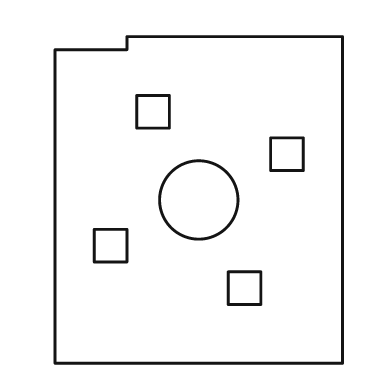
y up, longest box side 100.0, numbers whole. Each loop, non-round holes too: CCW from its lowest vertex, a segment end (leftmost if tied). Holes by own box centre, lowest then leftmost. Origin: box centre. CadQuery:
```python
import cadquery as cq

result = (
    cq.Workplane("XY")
    .moveTo(-44.0, -50.0)
    .lineTo(44.0, -50.0)
    .lineTo(44.0, 50.0)
    .lineTo(-22.0, 50.0)
    .lineTo(-22.0, 46.0)
    .lineTo(-44.0, 46.0)
    .close()
    .moveTo(9.0, -32.0)
    .lineTo(19.0, -32.0)
    .lineTo(19.0, -22.0)
    .lineTo(9.0, -22.0)
    .close()
    .moveTo(-32.0, -19.0)
    .lineTo(-22.0, -19.0)
    .lineTo(-22.0, -9.0)
    .lineTo(-32.0, -9.0)
    .close()
    .moveTo(0.0, 0.0)
    .circle(12.0)
    .moveTo(22.0, 9.0)
    .lineTo(32.0, 9.0)
    .lineTo(32.0, 19.0)
    .lineTo(22.0, 19.0)
    .close()
    .moveTo(-19.0, 22.0)
    .lineTo(-9.0, 22.0)
    .lineTo(-9.0, 32.0)
    .lineTo(-19.0, 32.0)
    .close()
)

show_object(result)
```